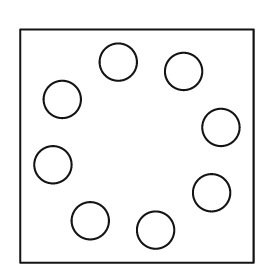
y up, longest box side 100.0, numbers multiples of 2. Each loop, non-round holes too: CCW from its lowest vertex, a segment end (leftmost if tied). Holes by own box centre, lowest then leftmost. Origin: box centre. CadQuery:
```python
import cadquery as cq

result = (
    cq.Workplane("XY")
    .moveTo(-50.0, -50.0)
    .lineTo(50.0, -50.0)
    .lineTo(50.0, 50.0)
    .lineTo(-50.0, 50.0)
    .close()
    .moveTo(8.0, -36.0)
    .circle(8.0)
    .moveTo(-20.0, -32.0)
    .circle(8.0)
    .moveTo(32.0, -20.0)
    .circle(8.0)
    .moveTo(-36.0, -8.0)
    .circle(8.0)
    .moveTo(36.0, 8.0)
    .circle(8.0)
    .moveTo(-32.0, 20.0)
    .circle(8.0)
    .moveTo(20.0, 32.0)
    .circle(8.0)
    .moveTo(-8.0, 36.0)
    .circle(8.0)
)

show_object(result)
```